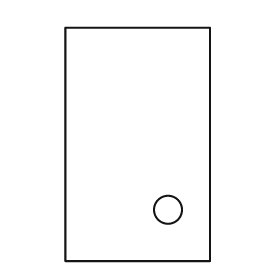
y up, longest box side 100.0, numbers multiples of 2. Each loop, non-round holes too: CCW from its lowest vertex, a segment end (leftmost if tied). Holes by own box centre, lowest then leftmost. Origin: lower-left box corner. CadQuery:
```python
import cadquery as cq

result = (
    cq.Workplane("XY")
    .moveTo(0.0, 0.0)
    .lineTo(62.0, 0.0)
    .lineTo(62.0, 100.0)
    .lineTo(0.0, 100.0)
    .close()
    .moveTo(44.0, 22.0)
    .circle(6.0)
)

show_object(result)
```